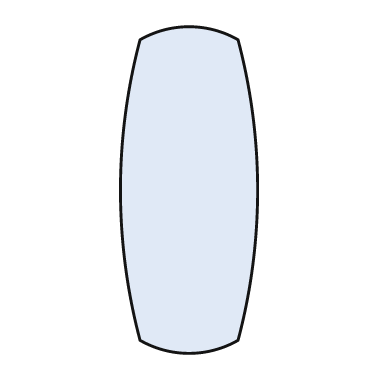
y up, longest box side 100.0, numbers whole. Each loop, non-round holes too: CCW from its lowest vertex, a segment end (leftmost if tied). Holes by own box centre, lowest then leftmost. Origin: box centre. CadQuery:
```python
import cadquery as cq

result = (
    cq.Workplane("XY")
    .moveTo(-15.0, -46.0)
    .threePointArc((0.0, -50.0), (15.0, -46.0))
    .threePointArc((21.0, 0.0), (15.0, 46.0))
    .threePointArc((0.0, 50.0), (-15.0, 46.0))
    .threePointArc((-21.0, 0.0), (-15.0, -46.0))
    .close()
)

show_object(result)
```